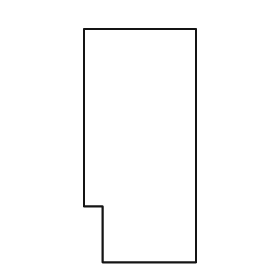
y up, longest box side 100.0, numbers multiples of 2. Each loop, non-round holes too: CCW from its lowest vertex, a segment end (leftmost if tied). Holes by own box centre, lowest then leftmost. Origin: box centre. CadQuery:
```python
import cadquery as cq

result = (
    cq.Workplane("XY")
    .moveTo(-16.0, -50.0)
    .lineTo(24.0, -50.0)
    .lineTo(24.0, 50.0)
    .lineTo(-24.0, 50.0)
    .lineTo(-24.0, -26.0)
    .lineTo(-16.0, -26.0)
    .close()
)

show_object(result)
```